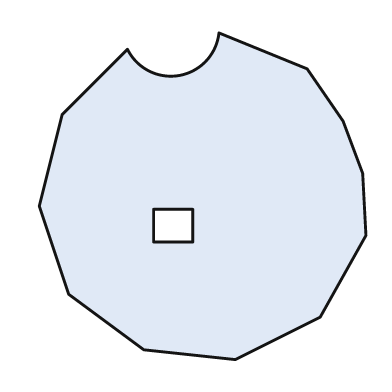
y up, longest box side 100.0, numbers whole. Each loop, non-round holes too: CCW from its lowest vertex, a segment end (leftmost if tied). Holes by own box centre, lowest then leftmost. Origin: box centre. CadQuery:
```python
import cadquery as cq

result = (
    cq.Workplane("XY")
    .moveTo(10.0, -50.0)
    .lineTo(36.0, -37.0)
    .lineTo(50.0, -12.0)
    .lineTo(49.0, 7.0)
    .lineTo(43.0, 23.0)
    .lineTo(32.0, 39.0)
    .lineTo(5.0, 50.0)
    .threePointArc((-7.0, 37.0), (-23.0, 45.0))
    .lineTo(-43.0, 25.0)
    .lineTo(-50.0, -3.0)
    .lineTo(-41.0, -30.0)
    .lineTo(-18.0, -47.0)
    .close()
    .moveTo(-15.0, -14.0)
    .lineTo(-3.0, -14.0)
    .lineTo(-3.0, -4.0)
    .lineTo(-15.0, -4.0)
    .close()
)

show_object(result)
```